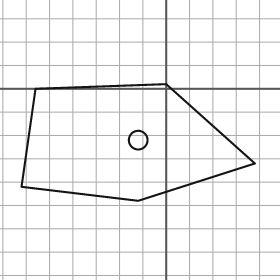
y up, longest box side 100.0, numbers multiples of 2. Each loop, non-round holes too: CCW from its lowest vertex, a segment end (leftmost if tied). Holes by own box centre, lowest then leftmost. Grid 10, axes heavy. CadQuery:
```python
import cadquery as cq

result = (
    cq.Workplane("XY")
    .moveTo(-12.0, -48.0)
    .lineTo(38.0, -32.0)
    .lineTo(0.0, 2.0)
    .lineTo(-56.0, 0.0)
    .lineTo(-62.0, -42.0)
    .close()
    .moveTo(-12.0, -22.0)
    .circle(4.0)
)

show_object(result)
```